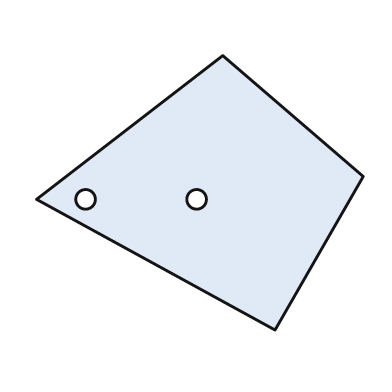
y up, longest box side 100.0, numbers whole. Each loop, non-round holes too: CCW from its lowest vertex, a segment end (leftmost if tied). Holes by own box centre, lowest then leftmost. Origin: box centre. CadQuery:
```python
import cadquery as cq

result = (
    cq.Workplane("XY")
    .moveTo(23.0, -42.0)
    .lineTo(50.0, 5.0)
    .lineTo(7.0, 42.0)
    .lineTo(-50.0, -2.0)
    .close()
    .moveTo(-35.0, -2.0)
    .circle(3.0)
    .moveTo(-1.0, -2.0)
    .circle(3.0)
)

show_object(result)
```